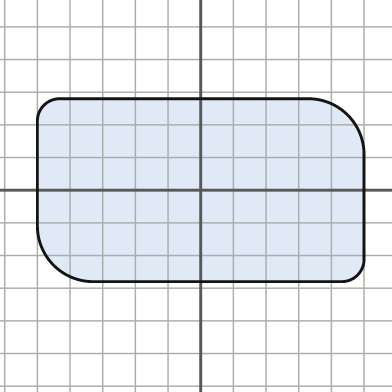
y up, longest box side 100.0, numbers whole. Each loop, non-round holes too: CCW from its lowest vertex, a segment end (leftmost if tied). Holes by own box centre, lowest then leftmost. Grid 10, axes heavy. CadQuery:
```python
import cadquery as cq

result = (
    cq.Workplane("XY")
    .moveTo(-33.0, -28.0)
    .lineTo(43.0, -28.0)
    .threePointArc((48.0, -26.0), (50.0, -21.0))
    .lineTo(50.0, 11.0)
    .threePointArc((45.0, 23.0), (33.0, 28.0))
    .lineTo(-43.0, 28.0)
    .threePointArc((-48.0, 26.0), (-50.0, 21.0))
    .lineTo(-50.0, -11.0)
    .threePointArc((-45.0, -23.0), (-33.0, -28.0))
    .close()
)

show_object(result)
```